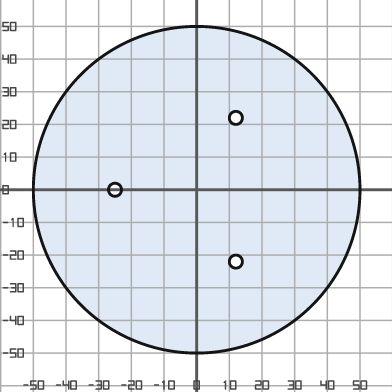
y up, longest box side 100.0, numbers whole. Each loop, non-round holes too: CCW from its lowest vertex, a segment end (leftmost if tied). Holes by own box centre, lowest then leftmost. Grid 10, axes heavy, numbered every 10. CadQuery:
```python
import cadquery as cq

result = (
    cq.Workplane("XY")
    .moveTo(0.0, 0.0)
    .circle(50.0)
    .moveTo(12.0, -22.0)
    .circle(2.0)
    .moveTo(-25.0, 0.0)
    .circle(2.0)
    .moveTo(12.0, 22.0)
    .circle(2.0)
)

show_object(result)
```